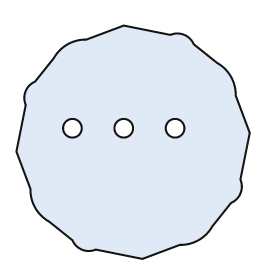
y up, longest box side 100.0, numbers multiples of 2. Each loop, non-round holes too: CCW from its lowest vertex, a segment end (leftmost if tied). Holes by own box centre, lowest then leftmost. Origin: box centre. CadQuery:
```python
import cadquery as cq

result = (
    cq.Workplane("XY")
    .moveTo(4.0, -50.0)
    .lineTo(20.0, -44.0)
    .threePointArc((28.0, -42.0), (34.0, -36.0))
    .lineTo(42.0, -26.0)
    .threePointArc((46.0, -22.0), (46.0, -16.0))
    .lineTo(50.0, 4.0)
    .lineTo(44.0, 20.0)
    .threePointArc((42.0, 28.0), (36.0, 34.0))
    .lineTo(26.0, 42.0)
    .threePointArc((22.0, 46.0), (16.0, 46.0))
    .lineTo(-4.0, 50.0)
    .lineTo(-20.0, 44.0)
    .threePointArc((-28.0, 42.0), (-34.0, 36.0))
    .lineTo(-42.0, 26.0)
    .threePointArc((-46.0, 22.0), (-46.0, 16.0))
    .lineTo(-50.0, -4.0)
    .lineTo(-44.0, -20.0)
    .threePointArc((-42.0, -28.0), (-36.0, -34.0))
    .lineTo(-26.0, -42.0)
    .threePointArc((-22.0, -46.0), (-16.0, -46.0))
    .close()
    .moveTo(-26.0, 6.0)
    .circle(4.0)
    .moveTo(-4.0, 6.0)
    .circle(4.0)
    .moveTo(18.0, 6.0)
    .circle(4.0)
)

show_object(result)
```